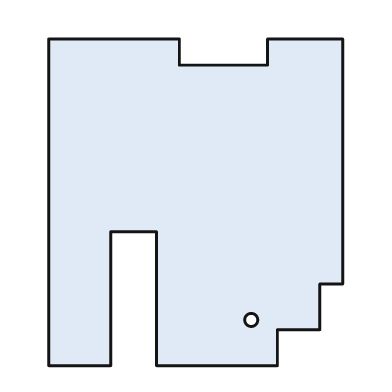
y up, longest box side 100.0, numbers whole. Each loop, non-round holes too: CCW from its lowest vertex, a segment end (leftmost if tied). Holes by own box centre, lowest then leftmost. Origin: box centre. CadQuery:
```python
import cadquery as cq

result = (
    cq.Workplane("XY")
    .moveTo(-45.0, -50.0)
    .lineTo(-26.0, -50.0)
    .lineTo(-26.0, -9.0)
    .lineTo(-12.0, -9.0)
    .lineTo(-12.0, -50.0)
    .lineTo(25.0, -50.0)
    .lineTo(25.0, -39.0)
    .lineTo(38.0, -39.0)
    .lineTo(38.0, -25.0)
    .lineTo(45.0, -25.0)
    .lineTo(45.0, 50.0)
    .lineTo(22.0, 50.0)
    .lineTo(22.0, 42.0)
    .lineTo(-5.0, 42.0)
    .lineTo(-5.0, 50.0)
    .lineTo(-45.0, 50.0)
    .close()
    .moveTo(17.0, -36.0)
    .circle(2.0)
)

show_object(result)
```